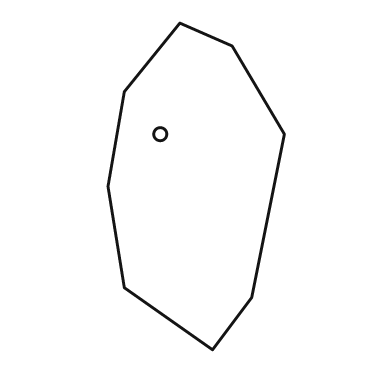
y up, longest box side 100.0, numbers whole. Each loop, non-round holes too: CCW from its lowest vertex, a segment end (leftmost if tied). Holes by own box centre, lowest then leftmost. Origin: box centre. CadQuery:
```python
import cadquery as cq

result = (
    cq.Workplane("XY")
    .moveTo(5.0, -50.0)
    .lineTo(17.0, -34.0)
    .lineTo(27.0, 16.0)
    .lineTo(11.0, 43.0)
    .lineTo(-5.0, 50.0)
    .lineTo(-22.0, 29.0)
    .lineTo(-27.0, 0.0)
    .lineTo(-22.0, -31.0)
    .close()
    .moveTo(-11.0, 16.0)
    .circle(2.0)
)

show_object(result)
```